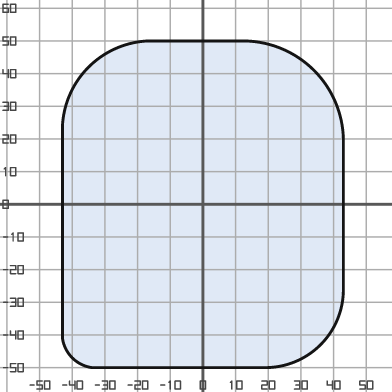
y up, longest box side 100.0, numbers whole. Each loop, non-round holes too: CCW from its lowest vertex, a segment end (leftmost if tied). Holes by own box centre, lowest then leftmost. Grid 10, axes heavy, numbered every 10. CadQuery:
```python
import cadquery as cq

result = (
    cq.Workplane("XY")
    .moveTo(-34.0, -50.0)
    .lineTo(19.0, -50.0)
    .threePointArc((36.0, -43.0), (43.0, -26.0))
    .lineTo(43.0, 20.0)
    .threePointArc((34.0, 41.0), (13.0, 50.0))
    .lineTo(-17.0, 50.0)
    .threePointArc((-35.0, 42.0), (-43.0, 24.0))
    .lineTo(-43.0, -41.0)
    .threePointArc((-40.0, -47.0), (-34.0, -50.0))
    .close()
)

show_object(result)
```